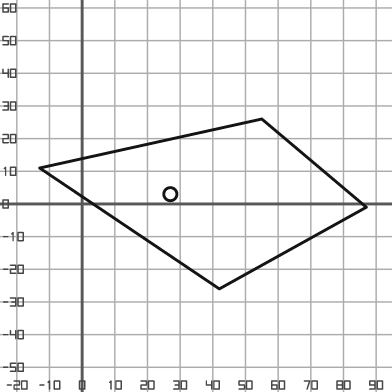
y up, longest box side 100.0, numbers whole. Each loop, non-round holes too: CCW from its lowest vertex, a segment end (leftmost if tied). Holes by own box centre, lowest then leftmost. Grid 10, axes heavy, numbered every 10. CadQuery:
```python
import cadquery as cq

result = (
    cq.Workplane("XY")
    .moveTo(42.0, -26.0)
    .lineTo(87.0, -1.0)
    .lineTo(55.0, 26.0)
    .lineTo(-13.0, 11.0)
    .close()
    .moveTo(27.0, 3.0)
    .circle(2.0)
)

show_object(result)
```